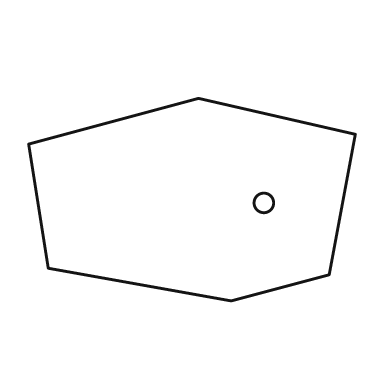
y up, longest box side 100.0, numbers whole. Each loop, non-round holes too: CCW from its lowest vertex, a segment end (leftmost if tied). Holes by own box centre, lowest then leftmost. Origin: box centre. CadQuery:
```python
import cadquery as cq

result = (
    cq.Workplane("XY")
    .moveTo(12.0, -31.0)
    .lineTo(42.0, -23.0)
    .lineTo(50.0, 20.0)
    .lineTo(2.0, 31.0)
    .lineTo(-50.0, 17.0)
    .lineTo(-44.0, -21.0)
    .close()
    .moveTo(22.0, -1.0)
    .circle(3.0)
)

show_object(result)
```